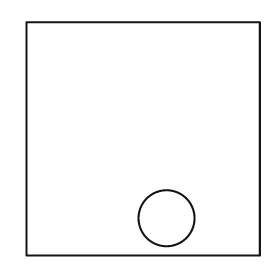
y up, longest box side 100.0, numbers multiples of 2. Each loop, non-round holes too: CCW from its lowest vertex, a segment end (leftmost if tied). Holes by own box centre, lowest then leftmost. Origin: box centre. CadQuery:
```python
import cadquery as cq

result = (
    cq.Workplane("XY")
    .moveTo(-50.0, -50.0)
    .lineTo(50.0, -50.0)
    .lineTo(50.0, 50.0)
    .lineTo(-50.0, 50.0)
    .close()
    .moveTo(10.0, -34.0)
    .circle(12.0)
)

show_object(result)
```